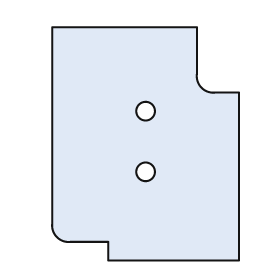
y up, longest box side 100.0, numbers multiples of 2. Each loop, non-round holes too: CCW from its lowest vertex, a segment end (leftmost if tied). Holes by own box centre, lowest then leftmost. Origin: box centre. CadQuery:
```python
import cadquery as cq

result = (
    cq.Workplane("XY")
    .moveTo(-16.0, -50.0)
    .lineTo(40.0, -50.0)
    .lineTo(40.0, 22.0)
    .lineTo(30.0, 22.0)
    .threePointArc((24.0, 24.0), (22.0, 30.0))
    .lineTo(22.0, 50.0)
    .lineTo(-40.0, 50.0)
    .lineTo(-40.0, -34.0)
    .threePointArc((-38.0, -40.0), (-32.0, -42.0))
    .lineTo(-16.0, -42.0)
    .close()
    .moveTo(0.0, -12.0)
    .circle(4.0)
    .moveTo(0.0, 14.0)
    .circle(4.0)
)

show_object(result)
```